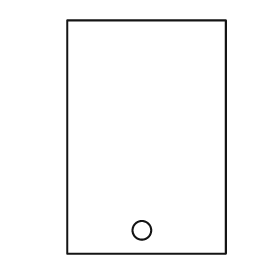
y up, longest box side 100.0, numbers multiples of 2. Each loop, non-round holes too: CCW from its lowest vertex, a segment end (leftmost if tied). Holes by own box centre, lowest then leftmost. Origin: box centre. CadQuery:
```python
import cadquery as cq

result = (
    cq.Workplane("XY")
    .moveTo(-34.0, -50.0)
    .lineTo(34.0, -50.0)
    .lineTo(34.0, 50.0)
    .lineTo(-34.0, 50.0)
    .close()
    .moveTo(-2.0, -40.0)
    .circle(4.0)
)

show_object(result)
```